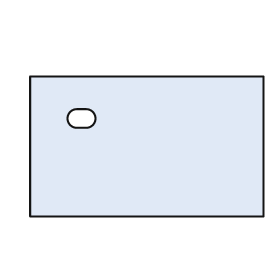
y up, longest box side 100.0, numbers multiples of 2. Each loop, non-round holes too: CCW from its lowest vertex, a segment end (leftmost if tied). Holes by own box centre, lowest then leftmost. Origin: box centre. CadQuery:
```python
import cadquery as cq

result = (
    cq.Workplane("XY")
    .moveTo(-50.0, -30.0)
    .lineTo(50.0, -30.0)
    .lineTo(50.0, 30.0)
    .lineTo(-50.0, 30.0)
    .close()
    .moveTo(-30.0, 8.0)
    .lineTo(-26.0, 8.0)
    .threePointArc((-22.0, 12.0), (-26.0, 16.0))
    .lineTo(-30.0, 16.0)
    .threePointArc((-34.0, 12.0), (-30.0, 8.0))
    .close()
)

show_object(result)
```